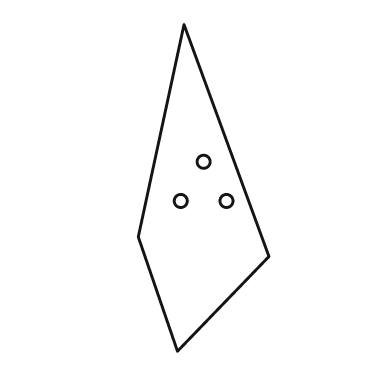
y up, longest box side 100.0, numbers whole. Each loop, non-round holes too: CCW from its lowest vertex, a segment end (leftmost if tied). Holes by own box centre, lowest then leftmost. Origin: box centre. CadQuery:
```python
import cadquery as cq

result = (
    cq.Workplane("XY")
    .moveTo(-8.0, -50.0)
    .lineTo(20.0, -21.0)
    .lineTo(-6.0, 50.0)
    .lineTo(-20.0, -15.0)
    .close()
    .moveTo(-7.0, -4.0)
    .circle(2.0)
    .moveTo(7.0, -4.0)
    .circle(2.0)
    .moveTo(0.0, 8.0)
    .circle(2.0)
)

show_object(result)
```